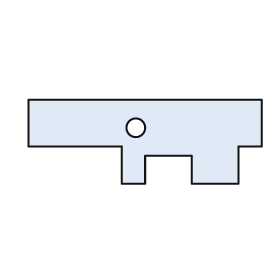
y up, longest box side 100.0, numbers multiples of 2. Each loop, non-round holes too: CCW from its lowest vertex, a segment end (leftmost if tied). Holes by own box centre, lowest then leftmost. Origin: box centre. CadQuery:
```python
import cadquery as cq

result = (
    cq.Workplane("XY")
    .moveTo(-10.0, -18.0)
    .lineTo(0.0, -18.0)
    .lineTo(0.0, -6.0)
    .lineTo(20.0, -6.0)
    .lineTo(20.0, -18.0)
    .lineTo(40.0, -18.0)
    .lineTo(40.0, -2.0)
    .lineTo(50.0, -2.0)
    .lineTo(50.0, 18.0)
    .lineTo(-50.0, 18.0)
    .lineTo(-50.0, -2.0)
    .lineTo(-10.0, -2.0)
    .close()
    .moveTo(-4.0, 6.0)
    .circle(4.0)
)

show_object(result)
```